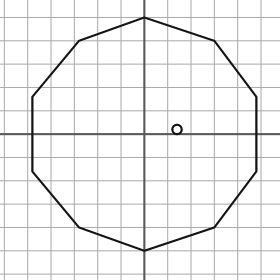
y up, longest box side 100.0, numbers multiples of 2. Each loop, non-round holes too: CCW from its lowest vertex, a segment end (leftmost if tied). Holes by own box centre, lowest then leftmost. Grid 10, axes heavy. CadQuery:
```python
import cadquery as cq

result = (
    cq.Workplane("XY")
    .moveTo(0.0, -50.0)
    .lineTo(30.0, -40.0)
    .lineTo(48.0, -16.0)
    .lineTo(48.0, 16.0)
    .lineTo(30.0, 40.0)
    .lineTo(0.0, 50.0)
    .lineTo(-28.0, 40.0)
    .lineTo(-48.0, 16.0)
    .lineTo(-48.0, -16.0)
    .lineTo(-28.0, -40.0)
    .close()
    .moveTo(14.0, 2.0)
    .circle(2.0)
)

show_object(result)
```